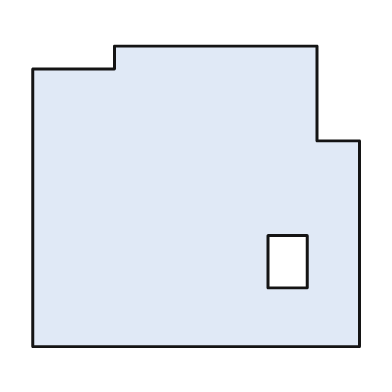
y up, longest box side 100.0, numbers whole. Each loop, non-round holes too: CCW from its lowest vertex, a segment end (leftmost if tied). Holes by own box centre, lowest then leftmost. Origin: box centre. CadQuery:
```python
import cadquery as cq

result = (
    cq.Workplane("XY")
    .moveTo(-50.0, -46.0)
    .lineTo(50.0, -46.0)
    .lineTo(50.0, 17.0)
    .lineTo(37.0, 17.0)
    .lineTo(37.0, 46.0)
    .lineTo(-25.0, 46.0)
    .lineTo(-25.0, 39.0)
    .lineTo(-50.0, 39.0)
    .close()
    .moveTo(22.0, -28.0)
    .lineTo(34.0, -28.0)
    .lineTo(34.0, -12.0)
    .lineTo(22.0, -12.0)
    .close()
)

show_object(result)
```